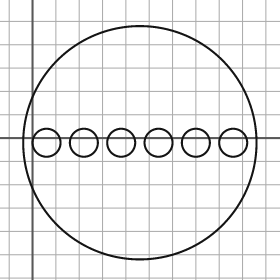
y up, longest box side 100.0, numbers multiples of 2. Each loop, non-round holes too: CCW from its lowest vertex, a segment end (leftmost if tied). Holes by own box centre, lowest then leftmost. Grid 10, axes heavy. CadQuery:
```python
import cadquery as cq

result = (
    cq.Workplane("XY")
    .moveTo(46.0, -2.0)
    .circle(50.0)
    .moveTo(6.0, -2.0)
    .circle(6.0)
    .moveTo(22.0, -2.0)
    .circle(6.0)
    .moveTo(38.0, -2.0)
    .circle(6.0)
    .moveTo(54.0, -2.0)
    .circle(6.0)
    .moveTo(70.0, -2.0)
    .circle(6.0)
    .moveTo(86.0, -2.0)
    .circle(6.0)
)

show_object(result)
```